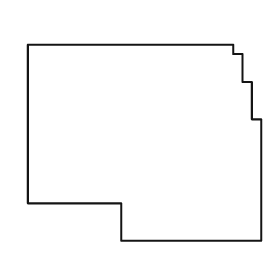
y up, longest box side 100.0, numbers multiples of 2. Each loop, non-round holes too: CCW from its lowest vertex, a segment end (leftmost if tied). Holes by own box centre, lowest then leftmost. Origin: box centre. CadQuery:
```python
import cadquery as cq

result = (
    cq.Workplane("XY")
    .moveTo(-10.0, -42.0)
    .lineTo(50.0, -42.0)
    .lineTo(50.0, 10.0)
    .lineTo(46.0, 10.0)
    .lineTo(46.0, 26.0)
    .lineTo(42.0, 26.0)
    .lineTo(42.0, 38.0)
    .lineTo(38.0, 38.0)
    .lineTo(38.0, 42.0)
    .lineTo(-50.0, 42.0)
    .lineTo(-50.0, -26.0)
    .lineTo(-10.0, -26.0)
    .close()
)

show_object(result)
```